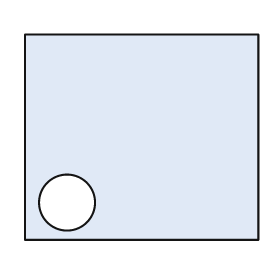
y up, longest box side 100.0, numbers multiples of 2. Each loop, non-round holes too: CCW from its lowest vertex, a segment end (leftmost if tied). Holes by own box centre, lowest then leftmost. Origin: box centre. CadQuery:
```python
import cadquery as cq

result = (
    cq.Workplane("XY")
    .moveTo(-50.0, -44.0)
    .lineTo(50.0, -44.0)
    .lineTo(50.0, 44.0)
    .lineTo(-50.0, 44.0)
    .close()
    .moveTo(-32.0, -28.0)
    .circle(12.0)
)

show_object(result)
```